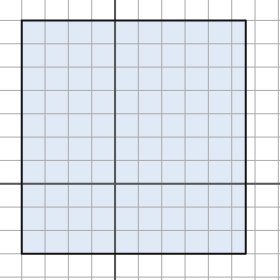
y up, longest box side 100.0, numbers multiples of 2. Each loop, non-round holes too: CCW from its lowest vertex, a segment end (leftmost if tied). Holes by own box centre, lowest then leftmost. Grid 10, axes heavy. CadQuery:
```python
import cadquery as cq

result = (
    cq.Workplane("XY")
    .moveTo(-40.0, -30.0)
    .lineTo(56.0, -30.0)
    .lineTo(56.0, 70.0)
    .lineTo(-40.0, 70.0)
    .close()
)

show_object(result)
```